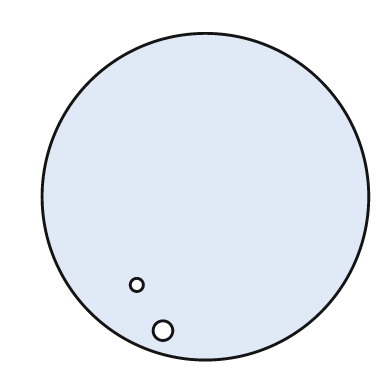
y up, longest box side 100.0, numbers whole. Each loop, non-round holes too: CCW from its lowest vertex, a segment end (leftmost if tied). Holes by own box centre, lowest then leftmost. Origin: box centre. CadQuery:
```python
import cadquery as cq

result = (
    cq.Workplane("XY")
    .moveTo(0.0, 0.0)
    .circle(50.0)
    .moveTo(-13.0, -41.0)
    .circle(3.0)
    .moveTo(-21.0, -27.0)
    .circle(2.0)
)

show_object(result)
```